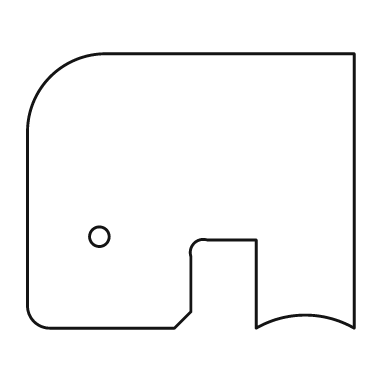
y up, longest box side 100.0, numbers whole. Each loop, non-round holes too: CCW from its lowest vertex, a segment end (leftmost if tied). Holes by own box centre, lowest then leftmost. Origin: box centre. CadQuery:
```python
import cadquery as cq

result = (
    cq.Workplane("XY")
    .moveTo(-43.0, -42.0)
    .lineTo(-5.0, -42.0)
    .lineTo(0.0, -37.0)
    .lineTo(0.0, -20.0)
    .threePointArc((1.0, -16.0), (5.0, -15.0))
    .lineTo(20.0, -15.0)
    .lineTo(20.0, -42.0)
    .threePointArc((35.0, -38.0), (50.0, -42.0))
    .lineTo(50.0, 42.0)
    .lineTo(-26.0, 42.0)
    .threePointArc((-43.0, 35.0), (-50.0, 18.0))
    .lineTo(-50.0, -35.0)
    .threePointArc((-48.0, -40.0), (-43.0, -42.0))
    .close()
    .moveTo(-28.0, -14.0)
    .circle(3.0)
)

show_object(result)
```